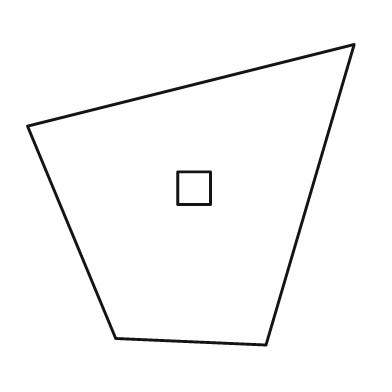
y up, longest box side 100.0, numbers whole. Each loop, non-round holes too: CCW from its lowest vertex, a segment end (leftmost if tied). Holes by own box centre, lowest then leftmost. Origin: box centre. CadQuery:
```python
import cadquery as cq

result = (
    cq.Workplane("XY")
    .moveTo(23.0, -46.0)
    .lineTo(50.0, 46.0)
    .lineTo(-50.0, 21.0)
    .lineTo(-23.0, -44.0)
    .close()
    .moveTo(-4.0, -3.0)
    .lineTo(6.0, -3.0)
    .lineTo(6.0, 7.0)
    .lineTo(-4.0, 7.0)
    .close()
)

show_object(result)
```